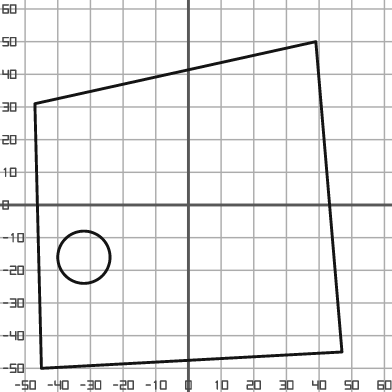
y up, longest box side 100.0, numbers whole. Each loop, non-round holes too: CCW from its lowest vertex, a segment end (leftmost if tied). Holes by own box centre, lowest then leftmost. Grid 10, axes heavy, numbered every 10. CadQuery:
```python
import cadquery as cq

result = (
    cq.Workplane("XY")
    .moveTo(-45.0, -50.0)
    .lineTo(47.0, -45.0)
    .lineTo(39.0, 50.0)
    .lineTo(-47.0, 31.0)
    .close()
    .moveTo(-32.0, -16.0)
    .circle(8.0)
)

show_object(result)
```